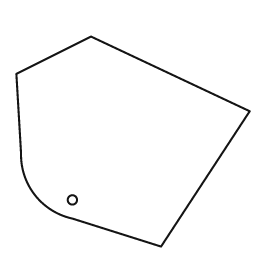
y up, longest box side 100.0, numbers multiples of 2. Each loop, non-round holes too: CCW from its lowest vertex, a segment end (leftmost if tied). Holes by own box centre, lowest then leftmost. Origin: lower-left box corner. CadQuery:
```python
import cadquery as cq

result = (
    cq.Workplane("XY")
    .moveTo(62.0, 0.0)
    .lineTo(100.0, 58.0)
    .lineTo(32.0, 90.0)
    .lineTo(0.0, 74.0)
    .lineTo(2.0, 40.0)
    .threePointArc((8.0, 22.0), (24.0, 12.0))
    .close()
    .moveTo(24.0, 20.0)
    .circle(2.0)
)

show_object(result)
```